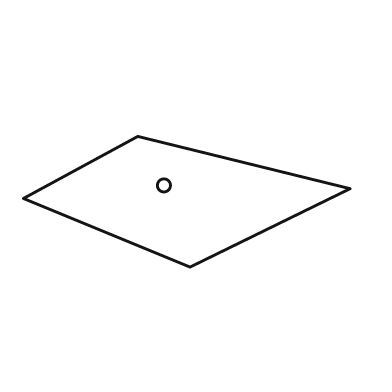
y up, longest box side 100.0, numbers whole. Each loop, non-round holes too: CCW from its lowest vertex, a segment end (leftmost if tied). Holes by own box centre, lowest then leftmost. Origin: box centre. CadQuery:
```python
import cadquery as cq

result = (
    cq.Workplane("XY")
    .moveTo(1.0, -20.0)
    .lineTo(50.0, 4.0)
    .lineTo(-15.0, 20.0)
    .lineTo(-50.0, 1.0)
    .close()
    .moveTo(-7.0, 5.0)
    .circle(2.0)
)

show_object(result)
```